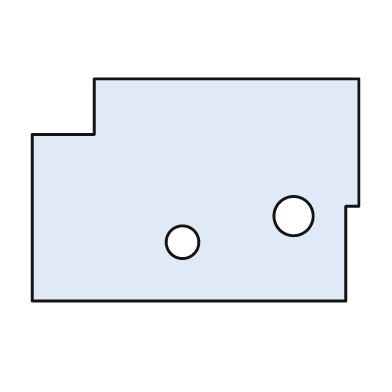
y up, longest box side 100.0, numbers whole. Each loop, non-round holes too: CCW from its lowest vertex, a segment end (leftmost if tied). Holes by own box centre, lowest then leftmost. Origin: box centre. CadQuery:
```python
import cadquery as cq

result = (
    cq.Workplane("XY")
    .moveTo(-50.0, -34.0)
    .lineTo(46.0, -34.0)
    .lineTo(46.0, -5.0)
    .lineTo(50.0, -5.0)
    .lineTo(50.0, 34.0)
    .lineTo(-31.0, 34.0)
    .lineTo(-31.0, 17.0)
    .lineTo(-50.0, 17.0)
    .close()
    .moveTo(-4.0, -16.0)
    .circle(5.0)
    .moveTo(30.0, -8.0)
    .circle(6.0)
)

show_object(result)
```